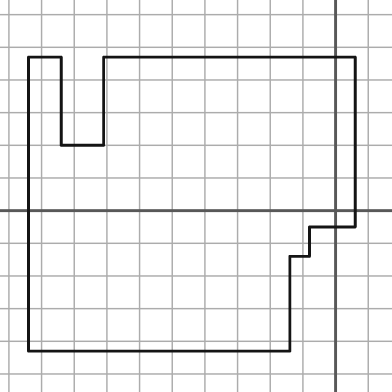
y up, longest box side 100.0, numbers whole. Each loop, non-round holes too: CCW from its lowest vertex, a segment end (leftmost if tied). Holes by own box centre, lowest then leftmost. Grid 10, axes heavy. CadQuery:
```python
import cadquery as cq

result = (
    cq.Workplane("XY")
    .moveTo(-94.0, -43.0)
    .lineTo(-14.0, -43.0)
    .lineTo(-14.0, -14.0)
    .lineTo(-8.0, -14.0)
    .lineTo(-8.0, -5.0)
    .lineTo(6.0, -5.0)
    .lineTo(6.0, 47.0)
    .lineTo(-71.0, 47.0)
    .lineTo(-71.0, 20.0)
    .lineTo(-84.0, 20.0)
    .lineTo(-84.0, 47.0)
    .lineTo(-94.0, 47.0)
    .close()
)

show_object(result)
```